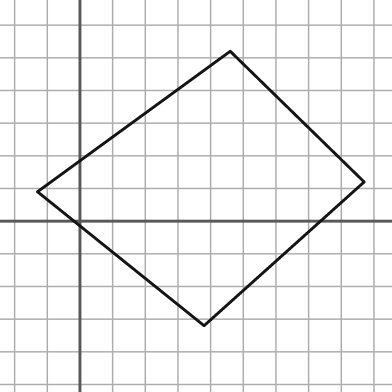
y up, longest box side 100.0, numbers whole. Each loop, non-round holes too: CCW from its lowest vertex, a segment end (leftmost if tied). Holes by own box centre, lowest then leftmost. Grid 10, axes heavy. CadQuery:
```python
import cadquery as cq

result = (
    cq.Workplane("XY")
    .moveTo(38.0, -32.0)
    .lineTo(87.0, 12.0)
    .lineTo(46.0, 52.0)
    .lineTo(-13.0, 9.0)
    .close()
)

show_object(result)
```